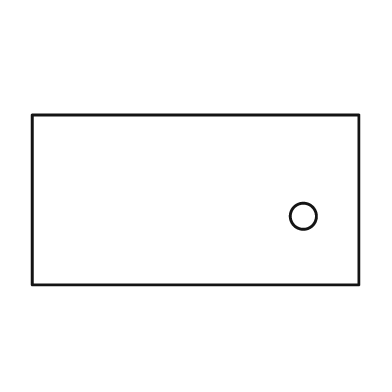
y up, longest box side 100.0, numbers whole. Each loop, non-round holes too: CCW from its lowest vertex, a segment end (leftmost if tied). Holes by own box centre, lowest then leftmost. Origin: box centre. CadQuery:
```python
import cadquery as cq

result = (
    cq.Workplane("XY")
    .moveTo(-50.0, -26.0)
    .lineTo(50.0, -26.0)
    .lineTo(50.0, 26.0)
    .lineTo(-50.0, 26.0)
    .close()
    .moveTo(33.0, -5.0)
    .circle(4.0)
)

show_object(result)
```